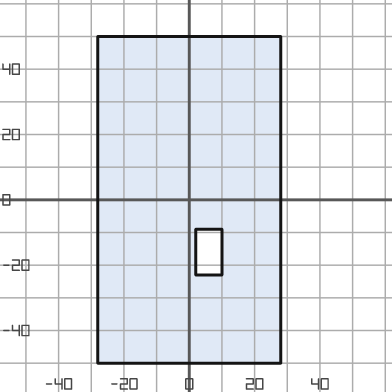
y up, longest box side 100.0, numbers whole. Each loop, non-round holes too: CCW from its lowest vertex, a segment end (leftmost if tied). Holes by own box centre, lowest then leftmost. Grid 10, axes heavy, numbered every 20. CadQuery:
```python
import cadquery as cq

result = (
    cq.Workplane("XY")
    .moveTo(-28.0, -50.0)
    .lineTo(28.0, -50.0)
    .lineTo(28.0, 50.0)
    .lineTo(-28.0, 50.0)
    .close()
    .moveTo(2.0, -23.0)
    .lineTo(10.0, -23.0)
    .lineTo(10.0, -9.0)
    .lineTo(2.0, -9.0)
    .close()
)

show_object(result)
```